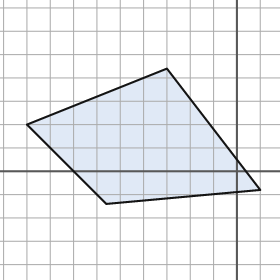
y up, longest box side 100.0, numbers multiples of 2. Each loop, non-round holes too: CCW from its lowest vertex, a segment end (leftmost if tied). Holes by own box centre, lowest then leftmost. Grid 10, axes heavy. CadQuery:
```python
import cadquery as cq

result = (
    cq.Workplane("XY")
    .moveTo(-56.0, -14.0)
    .lineTo(10.0, -8.0)
    .lineTo(-30.0, 44.0)
    .lineTo(-90.0, 20.0)
    .close()
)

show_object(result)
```